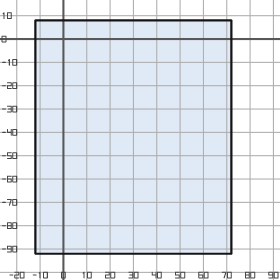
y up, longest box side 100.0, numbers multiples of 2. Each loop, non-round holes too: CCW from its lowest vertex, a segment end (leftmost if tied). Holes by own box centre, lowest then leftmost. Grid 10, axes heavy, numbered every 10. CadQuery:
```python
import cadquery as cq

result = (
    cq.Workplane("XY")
    .moveTo(-12.0, -92.0)
    .lineTo(72.0, -92.0)
    .lineTo(72.0, 8.0)
    .lineTo(-12.0, 8.0)
    .close()
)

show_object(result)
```